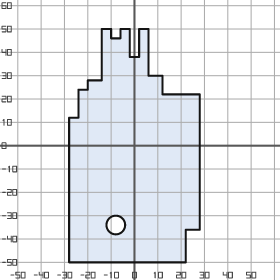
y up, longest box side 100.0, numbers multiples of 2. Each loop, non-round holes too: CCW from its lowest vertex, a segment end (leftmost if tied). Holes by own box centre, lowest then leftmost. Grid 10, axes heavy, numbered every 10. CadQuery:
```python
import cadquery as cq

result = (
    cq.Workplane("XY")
    .moveTo(-28.0, -50.0)
    .lineTo(22.0, -50.0)
    .lineTo(22.0, -36.0)
    .lineTo(28.0, -36.0)
    .lineTo(28.0, 22.0)
    .lineTo(12.0, 22.0)
    .lineTo(12.0, 30.0)
    .lineTo(6.0, 30.0)
    .lineTo(6.0, 50.0)
    .lineTo(2.0, 50.0)
    .lineTo(2.0, 38.0)
    .lineTo(-2.0, 38.0)
    .lineTo(-2.0, 50.0)
    .lineTo(-6.0, 50.0)
    .lineTo(-6.0, 46.0)
    .lineTo(-10.0, 46.0)
    .lineTo(-10.0, 50.0)
    .lineTo(-14.0, 50.0)
    .lineTo(-14.0, 28.0)
    .lineTo(-20.0, 28.0)
    .lineTo(-20.0, 24.0)
    .lineTo(-24.0, 24.0)
    .lineTo(-24.0, 12.0)
    .lineTo(-28.0, 12.0)
    .close()
    .moveTo(-8.0, -34.0)
    .circle(4.0)
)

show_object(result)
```